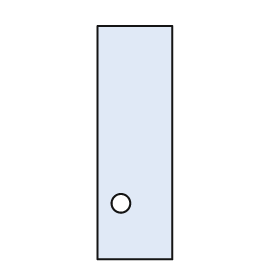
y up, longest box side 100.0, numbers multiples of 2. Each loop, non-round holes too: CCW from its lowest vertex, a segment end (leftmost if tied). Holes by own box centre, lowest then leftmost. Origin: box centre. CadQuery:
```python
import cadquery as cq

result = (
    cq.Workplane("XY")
    .moveTo(-16.0, -50.0)
    .lineTo(16.0, -50.0)
    .lineTo(16.0, 50.0)
    .lineTo(-16.0, 50.0)
    .close()
    .moveTo(-6.0, -26.0)
    .circle(4.0)
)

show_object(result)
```